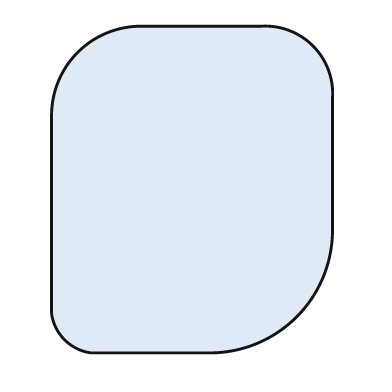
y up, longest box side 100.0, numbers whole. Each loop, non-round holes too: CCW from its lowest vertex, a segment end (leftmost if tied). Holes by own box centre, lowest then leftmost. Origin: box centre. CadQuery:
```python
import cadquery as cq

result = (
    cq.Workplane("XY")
    .moveTo(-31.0, -50.0)
    .lineTo(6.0, -50.0)
    .threePointArc((32.0, -39.0), (43.0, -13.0))
    .lineTo(43.0, 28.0)
    .threePointArc((37.0, 44.0), (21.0, 50.0))
    .lineTo(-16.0, 50.0)
    .threePointArc((-35.0, 42.0), (-43.0, 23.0))
    .lineTo(-43.0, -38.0)
    .threePointArc((-39.0, -46.0), (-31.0, -50.0))
    .close()
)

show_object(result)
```